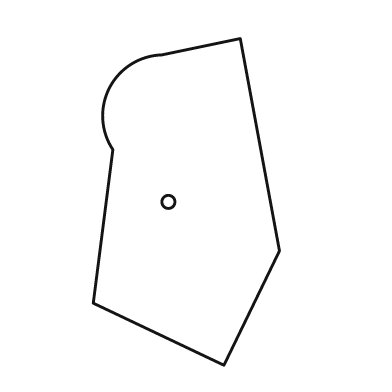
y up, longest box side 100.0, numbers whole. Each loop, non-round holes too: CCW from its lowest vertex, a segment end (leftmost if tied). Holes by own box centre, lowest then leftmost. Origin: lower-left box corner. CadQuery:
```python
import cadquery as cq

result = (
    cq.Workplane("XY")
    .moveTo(40.0, 0.0)
    .lineTo(57.0, 35.0)
    .lineTo(45.0, 100.0)
    .lineTo(21.0, 95.0)
    .threePointArc((5.0, 85.0), (6.0, 66.0))
    .lineTo(0.0, 19.0)
    .close()
    .moveTo(23.0, 50.0)
    .circle(2.0)
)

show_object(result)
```